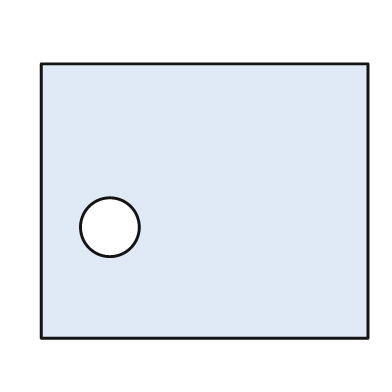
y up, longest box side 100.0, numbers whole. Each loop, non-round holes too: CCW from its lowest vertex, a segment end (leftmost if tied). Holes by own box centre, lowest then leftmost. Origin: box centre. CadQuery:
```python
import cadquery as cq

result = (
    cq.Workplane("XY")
    .moveTo(-50.0, -42.0)
    .lineTo(50.0, -42.0)
    .lineTo(50.0, 42.0)
    .lineTo(-50.0, 42.0)
    .close()
    .moveTo(-29.0, -8.0)
    .circle(9.0)
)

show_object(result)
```